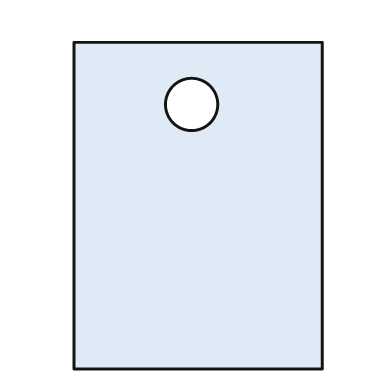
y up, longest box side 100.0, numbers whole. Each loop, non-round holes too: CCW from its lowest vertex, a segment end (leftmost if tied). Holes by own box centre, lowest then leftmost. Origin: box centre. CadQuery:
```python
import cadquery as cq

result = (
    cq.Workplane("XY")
    .moveTo(-38.0, -50.0)
    .lineTo(38.0, -50.0)
    .lineTo(38.0, 50.0)
    .lineTo(-38.0, 50.0)
    .close()
    .moveTo(-2.0, 31.0)
    .circle(8.0)
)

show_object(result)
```